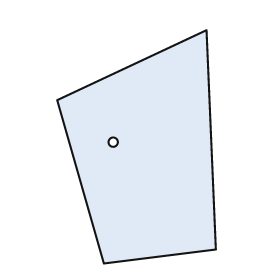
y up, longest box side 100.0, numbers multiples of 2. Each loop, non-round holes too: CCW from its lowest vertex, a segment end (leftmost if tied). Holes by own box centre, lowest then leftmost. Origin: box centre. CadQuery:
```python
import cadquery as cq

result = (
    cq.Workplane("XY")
    .moveTo(-14.0, -50.0)
    .lineTo(34.0, -44.0)
    .lineTo(30.0, 50.0)
    .lineTo(-34.0, 20.0)
    .close()
    .moveTo(-10.0, 2.0)
    .circle(2.0)
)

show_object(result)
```